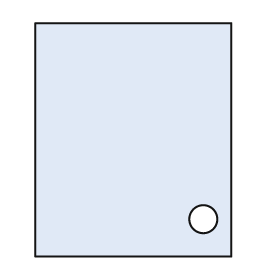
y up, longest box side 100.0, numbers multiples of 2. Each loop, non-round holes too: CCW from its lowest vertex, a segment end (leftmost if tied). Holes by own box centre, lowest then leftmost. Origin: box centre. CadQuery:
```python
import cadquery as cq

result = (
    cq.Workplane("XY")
    .moveTo(-42.0, -50.0)
    .lineTo(42.0, -50.0)
    .lineTo(42.0, 50.0)
    .lineTo(-42.0, 50.0)
    .close()
    .moveTo(30.0, -34.0)
    .circle(6.0)
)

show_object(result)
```